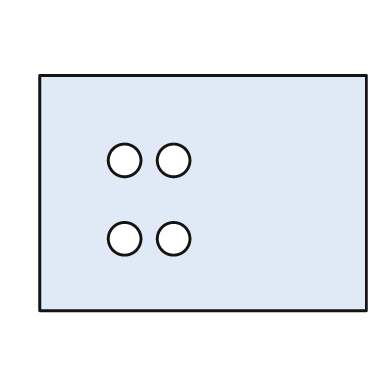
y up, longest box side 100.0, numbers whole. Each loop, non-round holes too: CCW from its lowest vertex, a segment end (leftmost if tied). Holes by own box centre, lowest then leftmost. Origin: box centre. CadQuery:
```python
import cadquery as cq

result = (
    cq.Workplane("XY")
    .moveTo(-50.0, -36.0)
    .lineTo(50.0, -36.0)
    .lineTo(50.0, 36.0)
    .lineTo(-50.0, 36.0)
    .close()
    .moveTo(-24.0, -14.0)
    .circle(5.0)
    .moveTo(-9.0, -14.0)
    .circle(5.0)
    .moveTo(-24.0, 10.0)
    .circle(5.0)
    .moveTo(-9.0, 10.0)
    .circle(5.0)
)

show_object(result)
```